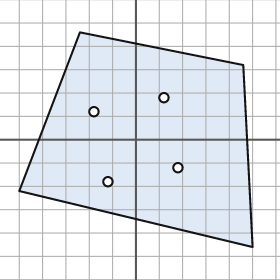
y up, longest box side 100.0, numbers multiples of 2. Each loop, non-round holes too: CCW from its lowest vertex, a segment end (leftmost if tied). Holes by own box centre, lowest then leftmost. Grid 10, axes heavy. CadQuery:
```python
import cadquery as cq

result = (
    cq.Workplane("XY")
    .moveTo(50.0, -46.0)
    .lineTo(46.0, 32.0)
    .lineTo(-24.0, 46.0)
    .lineTo(-50.0, -22.0)
    .close()
    .moveTo(-12.0, -18.0)
    .circle(2.0)
    .moveTo(18.0, -12.0)
    .circle(2.0)
    .moveTo(-18.0, 12.0)
    .circle(2.0)
    .moveTo(12.0, 18.0)
    .circle(2.0)
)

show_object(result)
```